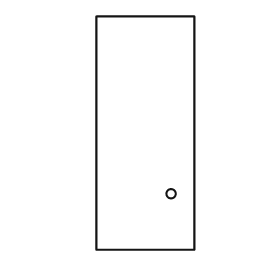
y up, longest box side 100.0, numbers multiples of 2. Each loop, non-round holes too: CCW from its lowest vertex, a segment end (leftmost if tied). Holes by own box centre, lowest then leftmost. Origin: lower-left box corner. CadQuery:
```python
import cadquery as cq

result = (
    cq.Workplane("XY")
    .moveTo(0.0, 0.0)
    .lineTo(42.0, 0.0)
    .lineTo(42.0, 100.0)
    .lineTo(0.0, 100.0)
    .close()
    .moveTo(32.0, 24.0)
    .circle(2.0)
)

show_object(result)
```